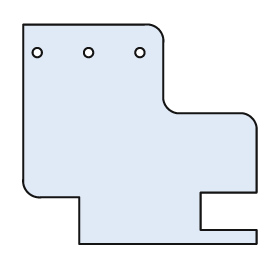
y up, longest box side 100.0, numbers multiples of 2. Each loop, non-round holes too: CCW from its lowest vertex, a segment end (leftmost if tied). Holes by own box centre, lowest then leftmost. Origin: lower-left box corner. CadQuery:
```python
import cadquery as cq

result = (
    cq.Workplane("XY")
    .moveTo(24.0, 0.0)
    .lineTo(100.0, 0.0)
    .lineTo(100.0, 6.0)
    .lineTo(76.0, 6.0)
    .lineTo(76.0, 22.0)
    .lineTo(100.0, 22.0)
    .lineTo(100.0, 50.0)
    .threePointArc((98.0, 54.0), (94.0, 56.0))
    .lineTo(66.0, 56.0)
    .threePointArc((62.0, 58.0), (60.0, 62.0))
    .lineTo(60.0, 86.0)
    .threePointArc((58.0, 92.0), (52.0, 94.0))
    .lineTo(0.0, 94.0)
    .lineTo(0.0, 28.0)
    .threePointArc((2.0, 22.0), (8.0, 20.0))
    .lineTo(24.0, 20.0)
    .close()
    .moveTo(6.0, 82.0)
    .circle(2.0)
    .moveTo(28.0, 82.0)
    .circle(2.0)
    .moveTo(50.0, 82.0)
    .circle(2.0)
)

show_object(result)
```